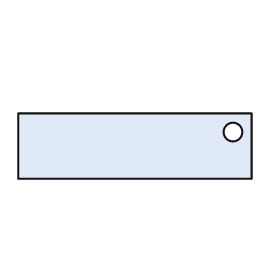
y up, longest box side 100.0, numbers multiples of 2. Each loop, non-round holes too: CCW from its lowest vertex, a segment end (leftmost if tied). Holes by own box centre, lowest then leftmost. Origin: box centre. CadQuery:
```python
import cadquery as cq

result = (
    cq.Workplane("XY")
    .moveTo(-50.0, -14.0)
    .lineTo(50.0, -14.0)
    .lineTo(50.0, 14.0)
    .lineTo(-50.0, 14.0)
    .close()
    .moveTo(42.0, 6.0)
    .circle(4.0)
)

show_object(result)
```